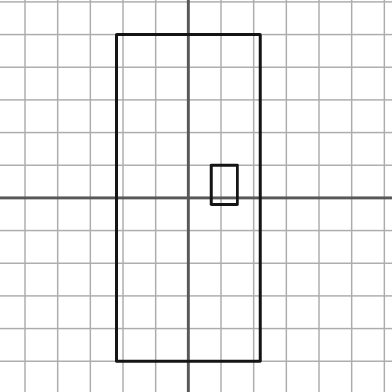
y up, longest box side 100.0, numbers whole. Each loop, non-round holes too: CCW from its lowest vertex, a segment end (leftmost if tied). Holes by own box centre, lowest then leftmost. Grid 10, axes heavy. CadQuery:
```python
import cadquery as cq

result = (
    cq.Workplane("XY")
    .moveTo(-22.0, -50.0)
    .lineTo(22.0, -50.0)
    .lineTo(22.0, 50.0)
    .lineTo(-22.0, 50.0)
    .close()
    .moveTo(7.0, -2.0)
    .lineTo(15.0, -2.0)
    .lineTo(15.0, 10.0)
    .lineTo(7.0, 10.0)
    .close()
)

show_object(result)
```